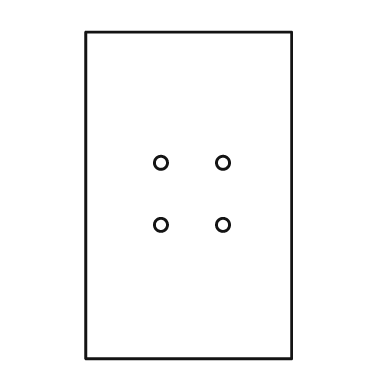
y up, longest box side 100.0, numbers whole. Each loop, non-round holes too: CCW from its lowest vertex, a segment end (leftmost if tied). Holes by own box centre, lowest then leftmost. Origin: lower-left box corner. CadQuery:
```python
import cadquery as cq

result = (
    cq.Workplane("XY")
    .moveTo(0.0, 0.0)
    .lineTo(63.0, 0.0)
    .lineTo(63.0, 100.0)
    .lineTo(0.0, 100.0)
    .close()
    .moveTo(23.0, 41.0)
    .circle(2.0)
    .moveTo(42.0, 41.0)
    .circle(2.0)
    .moveTo(23.0, 60.0)
    .circle(2.0)
    .moveTo(42.0, 60.0)
    .circle(2.0)
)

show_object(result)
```